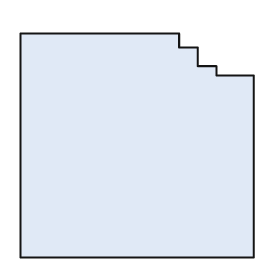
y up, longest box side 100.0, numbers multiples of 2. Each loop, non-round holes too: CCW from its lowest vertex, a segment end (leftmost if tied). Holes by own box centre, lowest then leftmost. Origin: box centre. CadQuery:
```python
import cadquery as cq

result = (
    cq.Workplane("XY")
    .moveTo(-50.0, -48.0)
    .lineTo(50.0, -48.0)
    .lineTo(50.0, 30.0)
    .lineTo(34.0, 30.0)
    .lineTo(34.0, 34.0)
    .lineTo(26.0, 34.0)
    .lineTo(26.0, 42.0)
    .lineTo(18.0, 42.0)
    .lineTo(18.0, 48.0)
    .lineTo(-50.0, 48.0)
    .close()
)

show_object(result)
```